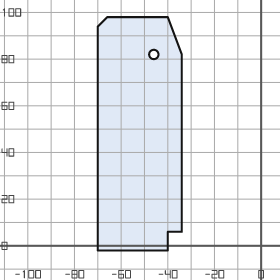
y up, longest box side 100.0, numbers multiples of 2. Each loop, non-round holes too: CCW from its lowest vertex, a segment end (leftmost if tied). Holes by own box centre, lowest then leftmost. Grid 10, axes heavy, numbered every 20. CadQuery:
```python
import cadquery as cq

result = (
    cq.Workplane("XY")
    .moveTo(-70.0, -2.0)
    .lineTo(-40.0, -2.0)
    .lineTo(-40.0, 6.0)
    .lineTo(-34.0, 6.0)
    .lineTo(-34.0, 82.0)
    .lineTo(-40.0, 98.0)
    .lineTo(-66.0, 98.0)
    .lineTo(-70.0, 94.0)
    .close()
    .moveTo(-46.0, 82.0)
    .circle(2.0)
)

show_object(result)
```